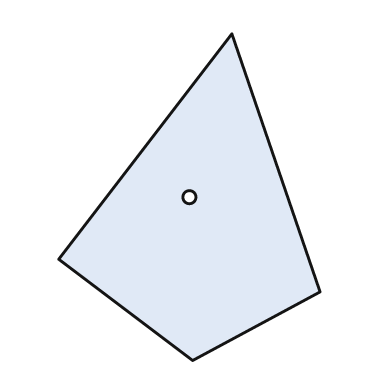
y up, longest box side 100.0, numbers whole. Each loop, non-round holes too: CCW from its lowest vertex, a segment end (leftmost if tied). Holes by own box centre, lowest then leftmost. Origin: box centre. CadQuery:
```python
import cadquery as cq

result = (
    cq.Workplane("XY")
    .moveTo(1.0, -50.0)
    .lineTo(40.0, -29.0)
    .lineTo(13.0, 50.0)
    .lineTo(-40.0, -19.0)
    .close()
    .moveTo(0.0, 0.0)
    .circle(2.0)
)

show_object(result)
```